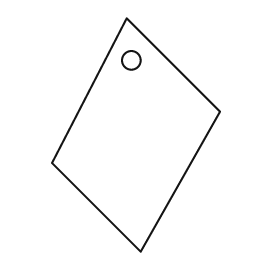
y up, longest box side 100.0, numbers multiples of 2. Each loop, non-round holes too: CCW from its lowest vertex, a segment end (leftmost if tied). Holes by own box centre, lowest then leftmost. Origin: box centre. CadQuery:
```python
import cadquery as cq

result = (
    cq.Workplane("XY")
    .moveTo(2.0, -50.0)
    .lineTo(36.0, 10.0)
    .lineTo(-4.0, 50.0)
    .lineTo(-36.0, -12.0)
    .close()
    .moveTo(-2.0, 32.0)
    .circle(4.0)
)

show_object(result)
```